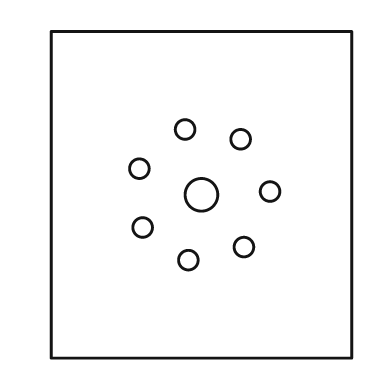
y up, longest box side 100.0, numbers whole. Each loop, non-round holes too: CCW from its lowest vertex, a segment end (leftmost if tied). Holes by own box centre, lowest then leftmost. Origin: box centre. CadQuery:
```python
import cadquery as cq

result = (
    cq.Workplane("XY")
    .moveTo(-46.0, -50.0)
    .lineTo(46.0, -50.0)
    .lineTo(46.0, 50.0)
    .lineTo(-46.0, 50.0)
    .close()
    .moveTo(-4.0, -20.0)
    .circle(3.0)
    .moveTo(13.0, -16.0)
    .circle(3.0)
    .moveTo(-18.0, -10.0)
    .circle(3.0)
    .moveTo(0.0, 0.0)
    .circle(5.0)
    .moveTo(21.0, 1.0)
    .circle(3.0)
    .moveTo(-19.0, 8.0)
    .circle(3.0)
    .moveTo(12.0, 17.0)
    .circle(3.0)
    .moveTo(-5.0, 20.0)
    .circle(3.0)
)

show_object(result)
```